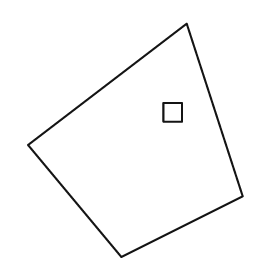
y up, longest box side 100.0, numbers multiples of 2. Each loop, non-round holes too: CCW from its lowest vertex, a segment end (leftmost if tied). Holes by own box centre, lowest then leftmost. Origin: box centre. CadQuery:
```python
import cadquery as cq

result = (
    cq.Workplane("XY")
    .moveTo(-6.0, -50.0)
    .lineTo(46.0, -24.0)
    .lineTo(22.0, 50.0)
    .lineTo(-46.0, -2.0)
    .close()
    .moveTo(12.0, 8.0)
    .lineTo(20.0, 8.0)
    .lineTo(20.0, 16.0)
    .lineTo(12.0, 16.0)
    .close()
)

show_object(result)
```